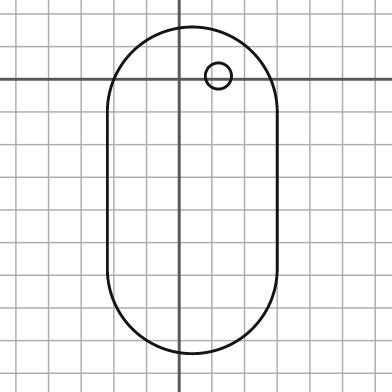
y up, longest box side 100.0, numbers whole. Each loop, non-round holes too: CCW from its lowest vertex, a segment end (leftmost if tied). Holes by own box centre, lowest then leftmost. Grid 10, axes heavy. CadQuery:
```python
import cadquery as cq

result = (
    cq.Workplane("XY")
    .moveTo(-22.0, -58.0)
    .threePointArc((4.0, -84.0), (30.0, -58.0))
    .lineTo(30.0, -10.0)
    .threePointArc((4.0, 16.0), (-22.0, -10.0))
    .close()
    .moveTo(12.0, 1.0)
    .circle(4.0)
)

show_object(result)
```